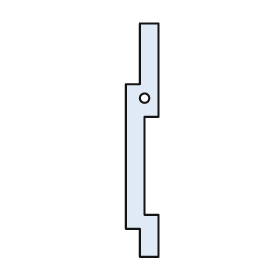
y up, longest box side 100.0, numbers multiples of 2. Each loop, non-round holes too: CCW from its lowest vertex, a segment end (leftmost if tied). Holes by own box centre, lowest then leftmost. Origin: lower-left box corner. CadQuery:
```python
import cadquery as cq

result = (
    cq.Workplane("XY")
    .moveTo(6.0, 0.0)
    .lineTo(14.0, 0.0)
    .lineTo(14.0, 18.0)
    .lineTo(8.0, 18.0)
    .lineTo(8.0, 60.0)
    .lineTo(14.0, 60.0)
    .lineTo(14.0, 100.0)
    .lineTo(6.0, 100.0)
    .lineTo(6.0, 74.0)
    .lineTo(0.0, 74.0)
    .lineTo(0.0, 12.0)
    .lineTo(6.0, 12.0)
    .close()
    .moveTo(8.0, 68.0)
    .circle(2.0)
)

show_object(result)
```